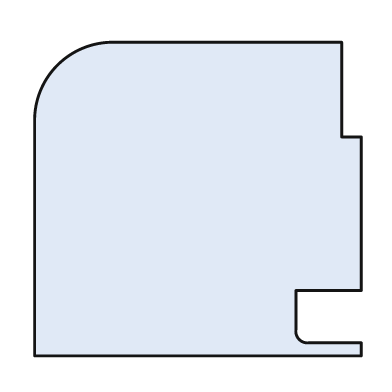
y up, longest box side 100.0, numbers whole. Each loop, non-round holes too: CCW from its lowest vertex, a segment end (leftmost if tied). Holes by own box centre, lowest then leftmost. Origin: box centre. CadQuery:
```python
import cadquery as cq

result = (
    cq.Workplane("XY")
    .moveTo(-50.0, -48.0)
    .lineTo(50.0, -48.0)
    .lineTo(50.0, -44.0)
    .lineTo(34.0, -44.0)
    .threePointArc((31.0, -43.0), (30.0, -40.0))
    .lineTo(30.0, -28.0)
    .lineTo(50.0, -28.0)
    .lineTo(50.0, 19.0)
    .lineTo(44.0, 19.0)
    .lineTo(44.0, 48.0)
    .lineTo(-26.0, 48.0)
    .threePointArc((-43.0, 41.0), (-50.0, 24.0))
    .close()
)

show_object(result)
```